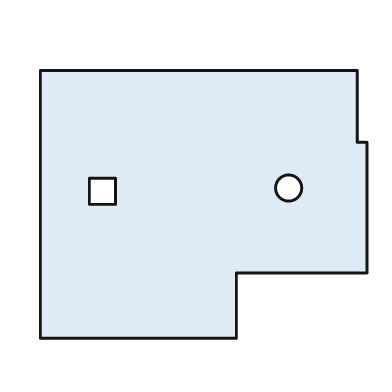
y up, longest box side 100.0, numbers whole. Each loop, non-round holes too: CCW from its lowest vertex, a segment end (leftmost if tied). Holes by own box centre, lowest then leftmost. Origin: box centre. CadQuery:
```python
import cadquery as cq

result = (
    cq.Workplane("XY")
    .moveTo(-50.0, -41.0)
    .lineTo(10.0, -41.0)
    .lineTo(10.0, -21.0)
    .lineTo(50.0, -21.0)
    .lineTo(50.0, 19.0)
    .lineTo(47.0, 19.0)
    .lineTo(47.0, 41.0)
    .lineTo(-50.0, 41.0)
    .close()
    .moveTo(-35.0, 0.0)
    .lineTo(-27.0, 0.0)
    .lineTo(-27.0, 8.0)
    .lineTo(-35.0, 8.0)
    .close()
    .moveTo(26.0, 5.0)
    .circle(4.0)
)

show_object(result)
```